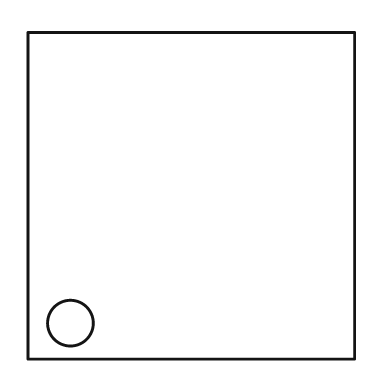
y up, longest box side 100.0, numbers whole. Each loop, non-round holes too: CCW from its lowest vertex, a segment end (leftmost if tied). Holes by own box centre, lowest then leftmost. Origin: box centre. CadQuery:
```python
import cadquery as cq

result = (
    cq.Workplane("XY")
    .moveTo(-50.0, -50.0)
    .lineTo(50.0, -50.0)
    .lineTo(50.0, 50.0)
    .lineTo(-50.0, 50.0)
    .close()
    .moveTo(-37.0, -39.0)
    .circle(7.0)
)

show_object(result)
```